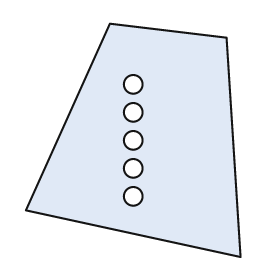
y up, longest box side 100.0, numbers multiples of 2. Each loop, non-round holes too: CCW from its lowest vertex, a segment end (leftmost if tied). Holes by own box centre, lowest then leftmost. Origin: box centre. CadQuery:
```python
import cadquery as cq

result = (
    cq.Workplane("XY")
    .moveTo(46.0, -50.0)
    .lineTo(40.0, 44.0)
    .lineTo(-10.0, 50.0)
    .lineTo(-46.0, -30.0)
    .close()
    .moveTo(0.0, -24.0)
    .circle(4.0)
    .moveTo(0.0, -12.0)
    .circle(4.0)
    .moveTo(0.0, 0.0)
    .circle(4.0)
    .moveTo(0.0, 12.0)
    .circle(4.0)
    .moveTo(0.0, 24.0)
    .circle(4.0)
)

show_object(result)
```